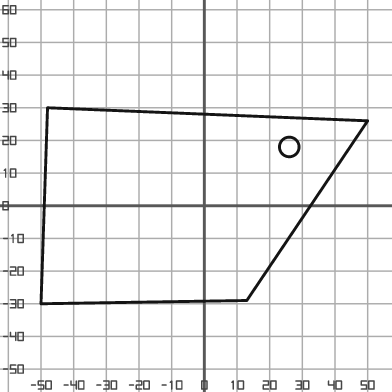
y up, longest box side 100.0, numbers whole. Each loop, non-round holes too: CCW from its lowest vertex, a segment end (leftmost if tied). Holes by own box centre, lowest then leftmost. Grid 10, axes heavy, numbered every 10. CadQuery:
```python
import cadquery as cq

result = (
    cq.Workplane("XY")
    .moveTo(-50.0, -30.0)
    .lineTo(13.0, -29.0)
    .lineTo(50.0, 26.0)
    .lineTo(-48.0, 30.0)
    .close()
    .moveTo(26.0, 18.0)
    .circle(3.0)
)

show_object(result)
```